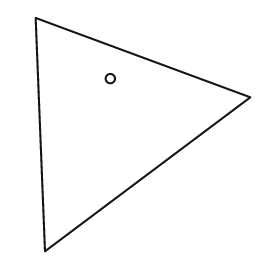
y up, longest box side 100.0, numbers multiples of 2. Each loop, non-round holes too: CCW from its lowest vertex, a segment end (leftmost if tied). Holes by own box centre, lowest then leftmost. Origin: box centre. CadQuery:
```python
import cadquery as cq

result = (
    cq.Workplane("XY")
    .moveTo(-42.0, -50.0)
    .lineTo(46.0, 16.0)
    .lineTo(-46.0, 50.0)
    .close()
    .moveTo(-14.0, 24.0)
    .circle(2.0)
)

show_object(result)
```